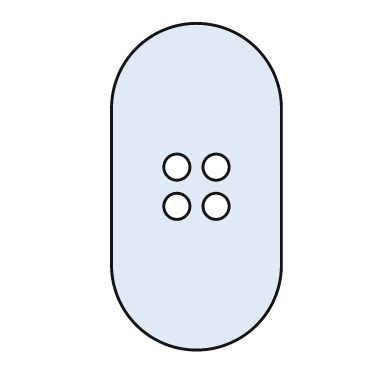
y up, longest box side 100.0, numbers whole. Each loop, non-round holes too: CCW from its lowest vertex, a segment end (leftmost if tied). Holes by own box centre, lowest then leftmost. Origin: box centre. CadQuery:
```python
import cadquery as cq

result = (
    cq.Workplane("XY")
    .moveTo(-26.0, -24.0)
    .threePointArc((0.0, -50.0), (26.0, -24.0))
    .lineTo(26.0, 24.0)
    .threePointArc((0.0, 50.0), (-26.0, 24.0))
    .close()
    .moveTo(-6.0, -6.0)
    .circle(4.0)
    .moveTo(6.0, -6.0)
    .circle(4.0)
    .moveTo(-6.0, 6.0)
    .circle(4.0)
    .moveTo(6.0, 6.0)
    .circle(4.0)
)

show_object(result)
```